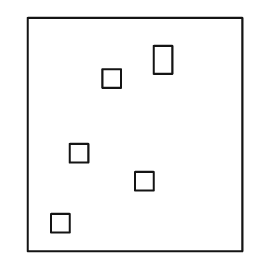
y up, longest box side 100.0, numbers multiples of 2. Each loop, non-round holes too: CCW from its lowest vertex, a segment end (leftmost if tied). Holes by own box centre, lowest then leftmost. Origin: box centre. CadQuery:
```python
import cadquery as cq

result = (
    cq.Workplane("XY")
    .moveTo(-46.0, -50.0)
    .lineTo(46.0, -50.0)
    .lineTo(46.0, 50.0)
    .lineTo(-46.0, 50.0)
    .close()
    .moveTo(-36.0, -42.0)
    .lineTo(-28.0, -42.0)
    .lineTo(-28.0, -34.0)
    .lineTo(-36.0, -34.0)
    .close()
    .moveTo(0.0, -24.0)
    .lineTo(8.0, -24.0)
    .lineTo(8.0, -16.0)
    .lineTo(0.0, -16.0)
    .close()
    .moveTo(-28.0, -12.0)
    .lineTo(-20.0, -12.0)
    .lineTo(-20.0, -4.0)
    .lineTo(-28.0, -4.0)
    .close()
    .moveTo(-14.0, 20.0)
    .lineTo(-6.0, 20.0)
    .lineTo(-6.0, 28.0)
    .lineTo(-14.0, 28.0)
    .close()
    .moveTo(8.0, 26.0)
    .lineTo(16.0, 26.0)
    .lineTo(16.0, 38.0)
    .lineTo(8.0, 38.0)
    .close()
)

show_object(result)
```